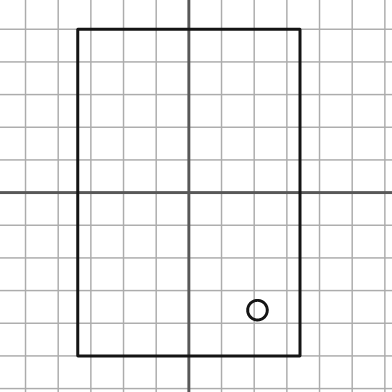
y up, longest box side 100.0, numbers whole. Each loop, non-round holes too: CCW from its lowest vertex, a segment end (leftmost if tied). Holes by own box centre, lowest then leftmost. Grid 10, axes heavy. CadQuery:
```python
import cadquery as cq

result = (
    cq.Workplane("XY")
    .moveTo(-34.0, -50.0)
    .lineTo(34.0, -50.0)
    .lineTo(34.0, 50.0)
    .lineTo(-34.0, 50.0)
    .close()
    .moveTo(21.0, -36.0)
    .circle(3.0)
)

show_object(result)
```